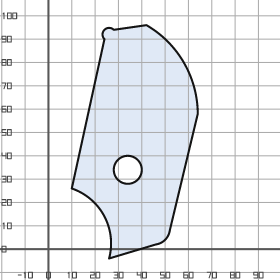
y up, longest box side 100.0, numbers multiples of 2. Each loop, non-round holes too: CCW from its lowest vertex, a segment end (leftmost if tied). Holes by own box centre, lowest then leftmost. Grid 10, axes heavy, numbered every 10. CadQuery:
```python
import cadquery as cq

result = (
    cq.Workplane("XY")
    .moveTo(26.0, -4.0)
    .lineTo(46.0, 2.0)
    .threePointArc((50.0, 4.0), (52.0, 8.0))
    .lineTo(64.0, 58.0)
    .threePointArc((58.0, 80.0), (42.0, 96.0))
    .lineTo(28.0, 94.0)
    .threePointArc((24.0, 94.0), (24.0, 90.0))
    .lineTo(10.0, 26.0)
    .threePointArc((24.0, 14.0), (26.0, -4.0))
    .close()
    .moveTo(34.0, 34.0)
    .circle(6.0)
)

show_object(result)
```